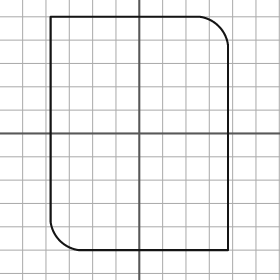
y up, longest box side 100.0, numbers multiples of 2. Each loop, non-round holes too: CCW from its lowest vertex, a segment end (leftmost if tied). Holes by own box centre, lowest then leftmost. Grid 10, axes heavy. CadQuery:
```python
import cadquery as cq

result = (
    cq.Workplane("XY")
    .moveTo(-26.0, -50.0)
    .lineTo(38.0, -50.0)
    .lineTo(38.0, 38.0)
    .threePointArc((34.0, 46.0), (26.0, 50.0))
    .lineTo(-38.0, 50.0)
    .lineTo(-38.0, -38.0)
    .threePointArc((-34.0, -46.0), (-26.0, -50.0))
    .close()
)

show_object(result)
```